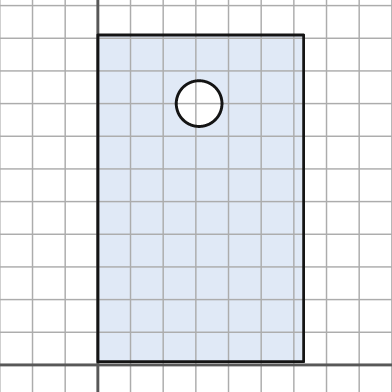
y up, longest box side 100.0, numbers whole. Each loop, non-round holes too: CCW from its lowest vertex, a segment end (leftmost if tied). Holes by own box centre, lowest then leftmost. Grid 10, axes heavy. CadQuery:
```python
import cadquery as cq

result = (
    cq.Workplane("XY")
    .moveTo(0.0, 1.0)
    .lineTo(63.0, 1.0)
    .lineTo(63.0, 101.0)
    .lineTo(0.0, 101.0)
    .close()
    .moveTo(31.0, 80.0)
    .circle(7.0)
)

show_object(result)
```